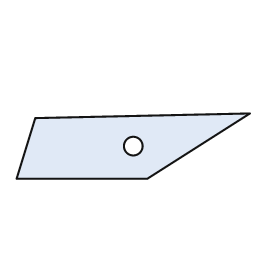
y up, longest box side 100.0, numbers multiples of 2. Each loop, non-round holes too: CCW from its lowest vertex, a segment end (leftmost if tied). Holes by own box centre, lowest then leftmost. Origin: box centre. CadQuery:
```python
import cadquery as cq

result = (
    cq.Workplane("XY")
    .moveTo(-50.0, -14.0)
    .lineTo(6.0, -14.0)
    .lineTo(50.0, 14.0)
    .lineTo(-42.0, 12.0)
    .close()
    .moveTo(0.0, 0.0)
    .circle(4.0)
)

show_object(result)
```